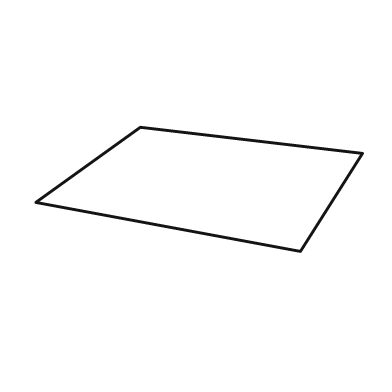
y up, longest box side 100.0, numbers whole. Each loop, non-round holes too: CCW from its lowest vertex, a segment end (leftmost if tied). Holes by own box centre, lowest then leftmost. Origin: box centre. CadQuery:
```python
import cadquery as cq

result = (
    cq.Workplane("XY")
    .moveTo(31.0, -19.0)
    .lineTo(50.0, 11.0)
    .lineTo(-18.0, 19.0)
    .lineTo(-50.0, -4.0)
    .close()
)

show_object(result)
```